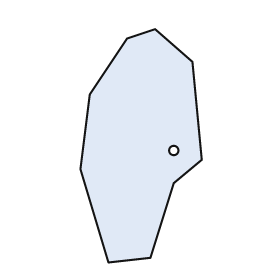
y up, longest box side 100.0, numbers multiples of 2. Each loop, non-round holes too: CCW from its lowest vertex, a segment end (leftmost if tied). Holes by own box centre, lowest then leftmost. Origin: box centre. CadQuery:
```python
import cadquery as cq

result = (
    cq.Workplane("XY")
    .moveTo(-14.0, -50.0)
    .lineTo(4.0, -48.0)
    .lineTo(14.0, -16.0)
    .lineTo(26.0, -6.0)
    .lineTo(22.0, 36.0)
    .lineTo(6.0, 50.0)
    .lineTo(-6.0, 46.0)
    .lineTo(-22.0, 22.0)
    .lineTo(-26.0, -10.0)
    .close()
    .moveTo(14.0, -2.0)
    .circle(2.0)
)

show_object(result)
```